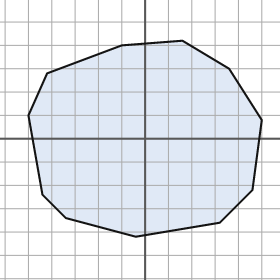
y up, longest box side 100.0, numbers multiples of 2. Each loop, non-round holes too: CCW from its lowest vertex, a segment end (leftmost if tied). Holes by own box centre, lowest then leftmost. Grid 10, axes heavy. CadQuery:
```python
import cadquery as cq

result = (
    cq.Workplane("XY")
    .moveTo(-4.0, -42.0)
    .lineTo(32.0, -36.0)
    .lineTo(46.0, -22.0)
    .lineTo(50.0, 8.0)
    .lineTo(36.0, 30.0)
    .lineTo(16.0, 42.0)
    .lineTo(-10.0, 40.0)
    .lineTo(-42.0, 28.0)
    .lineTo(-50.0, 10.0)
    .lineTo(-44.0, -24.0)
    .lineTo(-34.0, -34.0)
    .close()
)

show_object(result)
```